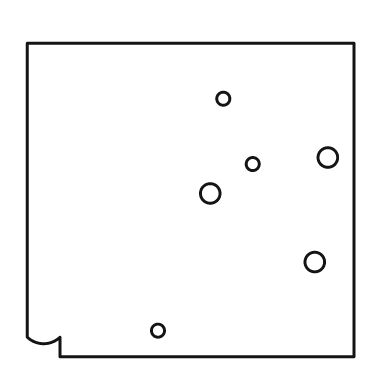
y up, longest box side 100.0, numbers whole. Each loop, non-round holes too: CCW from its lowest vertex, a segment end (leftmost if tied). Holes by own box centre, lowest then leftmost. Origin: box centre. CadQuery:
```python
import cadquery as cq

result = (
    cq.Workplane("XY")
    .moveTo(-40.0, -48.0)
    .lineTo(50.0, -48.0)
    .lineTo(50.0, 48.0)
    .lineTo(-50.0, 48.0)
    .lineTo(-50.0, -42.0)
    .threePointArc((-45.0, -44.0), (-40.0, -42.0))
    .close()
    .moveTo(-10.0, -40.0)
    .circle(2.0)
    .moveTo(38.0, -19.0)
    .circle(3.0)
    .moveTo(6.0, 2.0)
    .circle(3.0)
    .moveTo(19.0, 11.0)
    .circle(2.0)
    .moveTo(42.0, 13.0)
    .circle(3.0)
    .moveTo(10.0, 31.0)
    .circle(2.0)
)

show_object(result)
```